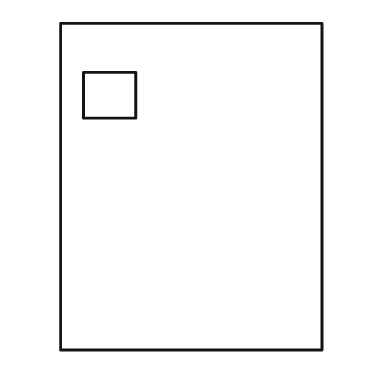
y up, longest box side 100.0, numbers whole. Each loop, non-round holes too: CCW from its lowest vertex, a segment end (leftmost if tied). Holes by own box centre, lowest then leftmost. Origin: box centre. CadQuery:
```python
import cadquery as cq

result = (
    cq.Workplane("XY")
    .moveTo(-40.0, -50.0)
    .lineTo(40.0, -50.0)
    .lineTo(40.0, 50.0)
    .lineTo(-40.0, 50.0)
    .close()
    .moveTo(-33.0, 21.0)
    .lineTo(-17.0, 21.0)
    .lineTo(-17.0, 35.0)
    .lineTo(-33.0, 35.0)
    .close()
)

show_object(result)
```